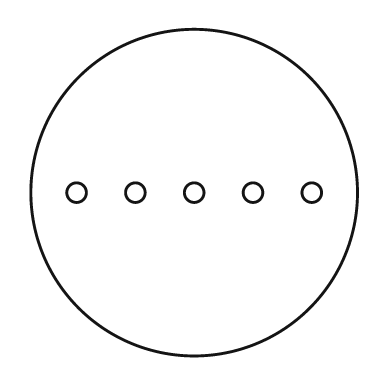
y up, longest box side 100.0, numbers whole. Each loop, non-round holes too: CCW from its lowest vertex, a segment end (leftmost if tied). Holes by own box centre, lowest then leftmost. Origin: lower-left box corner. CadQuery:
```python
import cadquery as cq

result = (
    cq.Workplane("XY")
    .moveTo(50.0, 50.0)
    .circle(50.0)
    .moveTo(14.0, 50.0)
    .circle(3.0)
    .moveTo(32.0, 50.0)
    .circle(3.0)
    .moveTo(50.0, 50.0)
    .circle(3.0)
    .moveTo(68.0, 50.0)
    .circle(3.0)
    .moveTo(86.0, 50.0)
    .circle(3.0)
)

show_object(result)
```